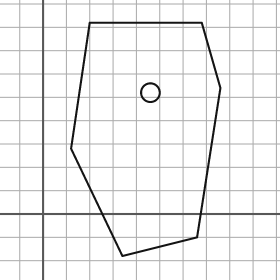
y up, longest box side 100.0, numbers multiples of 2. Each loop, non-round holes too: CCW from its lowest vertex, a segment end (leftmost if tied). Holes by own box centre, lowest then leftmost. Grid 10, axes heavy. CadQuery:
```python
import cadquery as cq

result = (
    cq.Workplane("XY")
    .moveTo(34.0, -18.0)
    .lineTo(66.0, -10.0)
    .lineTo(76.0, 54.0)
    .lineTo(68.0, 82.0)
    .lineTo(20.0, 82.0)
    .lineTo(12.0, 28.0)
    .close()
    .moveTo(46.0, 52.0)
    .circle(4.0)
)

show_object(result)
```